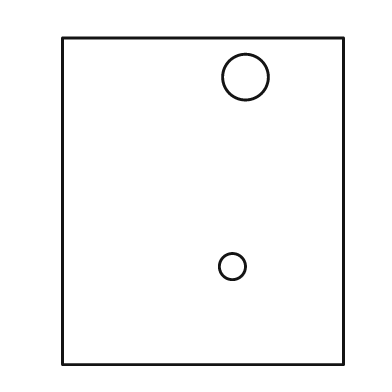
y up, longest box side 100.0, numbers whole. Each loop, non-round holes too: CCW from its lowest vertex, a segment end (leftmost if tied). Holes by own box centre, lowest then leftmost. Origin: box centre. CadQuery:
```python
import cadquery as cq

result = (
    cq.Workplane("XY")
    .moveTo(-43.0, -50.0)
    .lineTo(43.0, -50.0)
    .lineTo(43.0, 50.0)
    .lineTo(-43.0, 50.0)
    .close()
    .moveTo(9.0, -20.0)
    .circle(4.0)
    .moveTo(13.0, 38.0)
    .circle(7.0)
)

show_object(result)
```